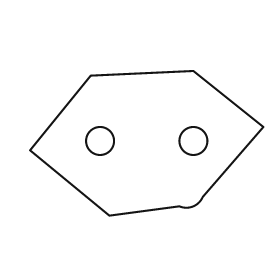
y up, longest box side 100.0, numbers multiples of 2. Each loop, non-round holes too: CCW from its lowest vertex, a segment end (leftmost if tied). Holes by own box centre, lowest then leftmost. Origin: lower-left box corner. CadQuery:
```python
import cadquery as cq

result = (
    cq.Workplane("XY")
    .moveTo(34.0, 0.0)
    .lineTo(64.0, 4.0)
    .threePointArc((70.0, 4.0), (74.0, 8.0))
    .lineTo(100.0, 38.0)
    .lineTo(70.0, 62.0)
    .lineTo(26.0, 60.0)
    .lineTo(0.0, 28.0)
    .close()
    .moveTo(30.0, 32.0)
    .circle(6.0)
    .moveTo(70.0, 32.0)
    .circle(6.0)
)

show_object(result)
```